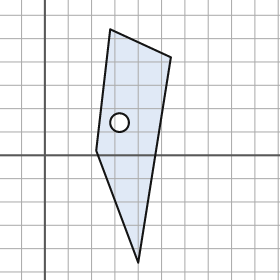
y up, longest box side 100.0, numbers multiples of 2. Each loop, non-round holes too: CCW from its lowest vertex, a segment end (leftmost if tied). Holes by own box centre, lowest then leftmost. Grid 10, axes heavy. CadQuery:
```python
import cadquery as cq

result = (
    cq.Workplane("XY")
    .moveTo(40.0, -46.0)
    .lineTo(54.0, 42.0)
    .lineTo(28.0, 54.0)
    .lineTo(22.0, 2.0)
    .close()
    .moveTo(32.0, 14.0)
    .circle(4.0)
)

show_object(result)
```